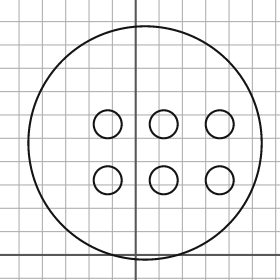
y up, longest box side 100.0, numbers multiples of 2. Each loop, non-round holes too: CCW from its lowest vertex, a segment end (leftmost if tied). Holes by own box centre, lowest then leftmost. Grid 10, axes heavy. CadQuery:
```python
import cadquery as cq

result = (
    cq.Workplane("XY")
    .moveTo(4.0, 48.0)
    .circle(50.0)
    .moveTo(-12.0, 32.0)
    .circle(6.0)
    .moveTo(12.0, 32.0)
    .circle(6.0)
    .moveTo(36.0, 32.0)
    .circle(6.0)
    .moveTo(-12.0, 56.0)
    .circle(6.0)
    .moveTo(12.0, 56.0)
    .circle(6.0)
    .moveTo(36.0, 56.0)
    .circle(6.0)
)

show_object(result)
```